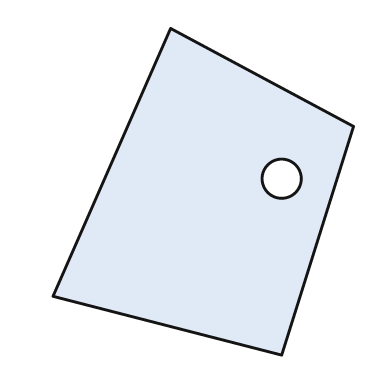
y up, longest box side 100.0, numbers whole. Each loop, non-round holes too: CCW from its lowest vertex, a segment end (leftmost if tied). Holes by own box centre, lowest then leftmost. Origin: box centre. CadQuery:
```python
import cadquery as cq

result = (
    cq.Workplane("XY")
    .moveTo(24.0, -50.0)
    .lineTo(46.0, 20.0)
    .lineTo(-10.0, 50.0)
    .lineTo(-46.0, -32.0)
    .close()
    .moveTo(24.0, 4.0)
    .circle(6.0)
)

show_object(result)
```